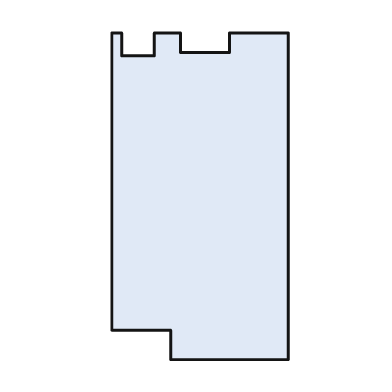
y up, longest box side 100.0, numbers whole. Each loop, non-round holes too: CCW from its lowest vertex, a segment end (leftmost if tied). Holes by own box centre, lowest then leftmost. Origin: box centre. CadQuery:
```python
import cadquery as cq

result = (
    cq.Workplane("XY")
    .moveTo(-9.0, -50.0)
    .lineTo(27.0, -50.0)
    .lineTo(27.0, 50.0)
    .lineTo(9.0, 50.0)
    .lineTo(9.0, 44.0)
    .lineTo(-6.0, 44.0)
    .lineTo(-6.0, 50.0)
    .lineTo(-14.0, 50.0)
    .lineTo(-14.0, 43.0)
    .lineTo(-24.0, 43.0)
    .lineTo(-24.0, 50.0)
    .lineTo(-27.0, 50.0)
    .lineTo(-27.0, -41.0)
    .lineTo(-9.0, -41.0)
    .close()
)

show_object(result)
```